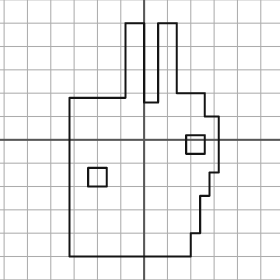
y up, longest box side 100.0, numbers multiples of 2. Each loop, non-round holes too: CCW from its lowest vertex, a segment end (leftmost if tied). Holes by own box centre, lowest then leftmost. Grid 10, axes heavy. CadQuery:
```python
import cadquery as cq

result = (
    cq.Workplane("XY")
    .moveTo(-32.0, -50.0)
    .lineTo(20.0, -50.0)
    .lineTo(20.0, -40.0)
    .lineTo(24.0, -40.0)
    .lineTo(24.0, -24.0)
    .lineTo(28.0, -24.0)
    .lineTo(28.0, -14.0)
    .lineTo(32.0, -14.0)
    .lineTo(32.0, 10.0)
    .lineTo(26.0, 10.0)
    .lineTo(26.0, 20.0)
    .lineTo(14.0, 20.0)
    .lineTo(14.0, 50.0)
    .lineTo(6.0, 50.0)
    .lineTo(6.0, 16.0)
    .lineTo(0.0, 16.0)
    .lineTo(0.0, 50.0)
    .lineTo(-8.0, 50.0)
    .lineTo(-8.0, 18.0)
    .lineTo(-32.0, 18.0)
    .close()
    .moveTo(-24.0, -20.0)
    .lineTo(-16.0, -20.0)
    .lineTo(-16.0, -12.0)
    .lineTo(-24.0, -12.0)
    .close()
    .moveTo(18.0, -6.0)
    .lineTo(26.0, -6.0)
    .lineTo(26.0, 2.0)
    .lineTo(18.0, 2.0)
    .close()
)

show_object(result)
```